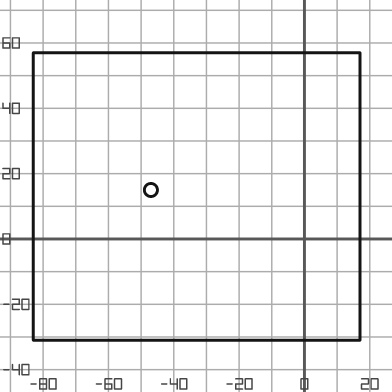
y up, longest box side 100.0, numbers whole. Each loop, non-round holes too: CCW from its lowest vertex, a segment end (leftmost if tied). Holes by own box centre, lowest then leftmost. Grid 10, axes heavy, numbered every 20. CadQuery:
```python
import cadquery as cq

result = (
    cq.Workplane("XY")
    .moveTo(-83.0, -31.0)
    .lineTo(17.0, -31.0)
    .lineTo(17.0, 57.0)
    .lineTo(-83.0, 57.0)
    .close()
    .moveTo(-47.0, 15.0)
    .circle(2.0)
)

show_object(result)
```